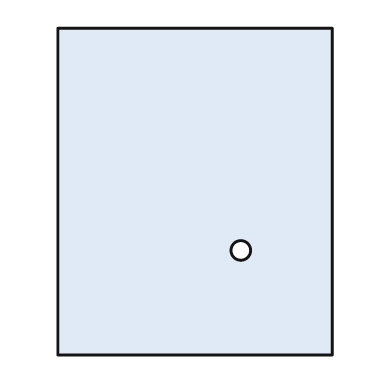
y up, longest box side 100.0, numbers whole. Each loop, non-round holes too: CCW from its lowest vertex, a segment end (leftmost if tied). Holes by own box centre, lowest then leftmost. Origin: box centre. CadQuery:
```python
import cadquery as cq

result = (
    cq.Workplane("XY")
    .moveTo(-42.0, -50.0)
    .lineTo(42.0, -50.0)
    .lineTo(42.0, 50.0)
    .lineTo(-42.0, 50.0)
    .close()
    .moveTo(14.0, -18.0)
    .circle(3.0)
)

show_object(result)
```